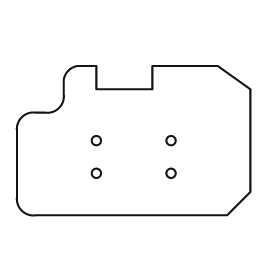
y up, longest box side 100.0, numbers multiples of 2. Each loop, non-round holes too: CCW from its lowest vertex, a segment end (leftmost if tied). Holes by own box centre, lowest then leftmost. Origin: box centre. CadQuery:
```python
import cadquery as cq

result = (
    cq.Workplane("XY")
    .moveTo(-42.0, -32.0)
    .lineTo(40.0, -32.0)
    .lineTo(50.0, -22.0)
    .lineTo(50.0, 22.0)
    .lineTo(36.0, 32.0)
    .lineTo(8.0, 32.0)
    .lineTo(8.0, 22.0)
    .lineTo(-16.0, 22.0)
    .lineTo(-16.0, 32.0)
    .lineTo(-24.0, 32.0)
    .threePointArc((-28.0, 30.0), (-30.0, 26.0))
    .lineTo(-30.0, 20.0)
    .threePointArc((-32.0, 14.0), (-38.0, 12.0))
    .lineTo(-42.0, 12.0)
    .threePointArc((-48.0, 10.0), (-50.0, 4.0))
    .lineTo(-50.0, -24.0)
    .threePointArc((-48.0, -30.0), (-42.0, -32.0))
    .close()
    .moveTo(-16.0, -14.0)
    .circle(2.0)
    .moveTo(16.0, -14.0)
    .circle(2.0)
    .moveTo(-16.0, 0.0)
    .circle(2.0)
    .moveTo(16.0, 0.0)
    .circle(2.0)
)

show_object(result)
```